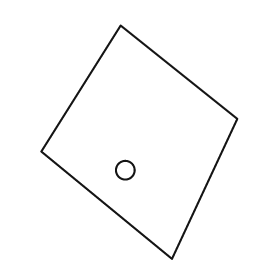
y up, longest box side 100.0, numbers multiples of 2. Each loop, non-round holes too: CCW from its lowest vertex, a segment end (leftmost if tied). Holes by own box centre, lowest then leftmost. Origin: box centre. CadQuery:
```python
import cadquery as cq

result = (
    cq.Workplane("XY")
    .moveTo(14.0, -50.0)
    .lineTo(42.0, 10.0)
    .lineTo(-8.0, 50.0)
    .lineTo(-42.0, -4.0)
    .close()
    .moveTo(-6.0, -12.0)
    .circle(4.0)
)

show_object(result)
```